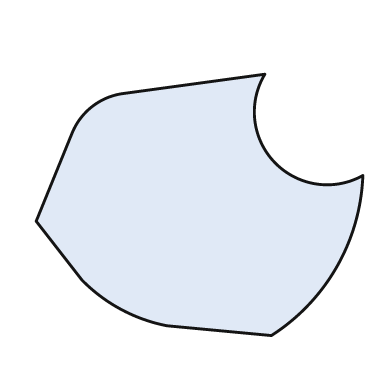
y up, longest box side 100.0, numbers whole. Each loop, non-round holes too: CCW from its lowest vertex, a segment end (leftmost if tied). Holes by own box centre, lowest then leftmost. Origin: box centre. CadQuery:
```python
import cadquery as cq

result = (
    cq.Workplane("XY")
    .moveTo(22.0, -40.0)
    .threePointArc((42.0, -19.0), (50.0, 9.0))
    .threePointArc((23.0, 13.0), (20.0, 40.0))
    .lineTo(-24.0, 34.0)
    .threePointArc((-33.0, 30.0), (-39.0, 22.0))
    .lineTo(-50.0, -5.0)
    .lineTo(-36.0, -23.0)
    .threePointArc((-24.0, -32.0), (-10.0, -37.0))
    .close()
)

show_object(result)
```